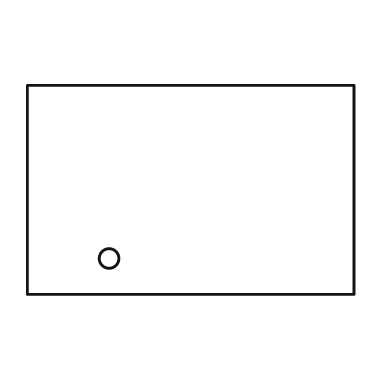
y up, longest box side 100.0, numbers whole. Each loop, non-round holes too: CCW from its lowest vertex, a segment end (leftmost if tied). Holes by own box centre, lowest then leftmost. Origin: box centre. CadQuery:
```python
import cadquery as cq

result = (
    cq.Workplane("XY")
    .moveTo(-50.0, -32.0)
    .lineTo(50.0, -32.0)
    .lineTo(50.0, 32.0)
    .lineTo(-50.0, 32.0)
    .close()
    .moveTo(-25.0, -21.0)
    .circle(3.0)
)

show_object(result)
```